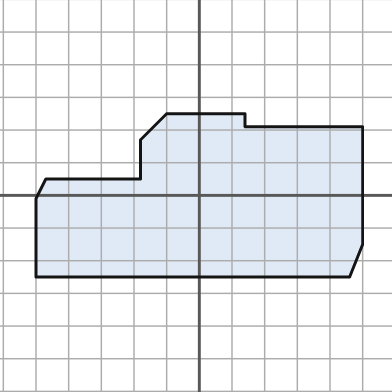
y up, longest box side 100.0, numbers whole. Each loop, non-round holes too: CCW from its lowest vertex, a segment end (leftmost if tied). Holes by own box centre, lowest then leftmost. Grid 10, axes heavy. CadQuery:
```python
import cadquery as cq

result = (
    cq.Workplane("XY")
    .moveTo(-50.0, -25.0)
    .lineTo(46.0, -25.0)
    .lineTo(50.0, -15.0)
    .lineTo(50.0, 21.0)
    .lineTo(14.0, 21.0)
    .lineTo(14.0, 25.0)
    .lineTo(-10.0, 25.0)
    .lineTo(-18.0, 17.0)
    .lineTo(-18.0, 5.0)
    .lineTo(-47.0, 5.0)
    .lineTo(-50.0, -1.0)
    .close()
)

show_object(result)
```